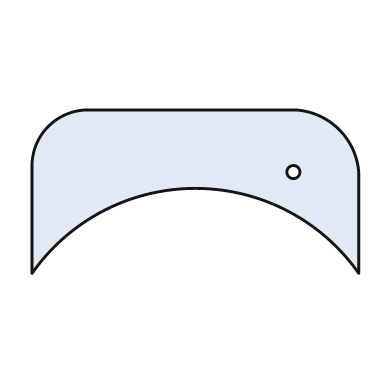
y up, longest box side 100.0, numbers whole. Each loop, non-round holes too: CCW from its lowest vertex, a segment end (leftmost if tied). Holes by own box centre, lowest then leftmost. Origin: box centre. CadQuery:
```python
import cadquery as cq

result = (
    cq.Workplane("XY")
    .moveTo(-50.0, -25.0)
    .threePointArc((0.0, 1.0), (50.0, -25.0))
    .lineTo(50.0, 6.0)
    .threePointArc((44.0, 19.0), (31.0, 25.0))
    .lineTo(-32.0, 25.0)
    .threePointArc((-45.0, 20.0), (-50.0, 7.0))
    .close()
    .moveTo(30.0, 6.0)
    .circle(2.0)
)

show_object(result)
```